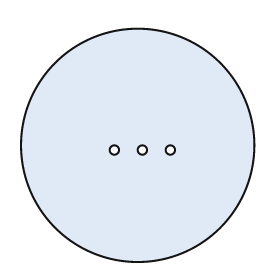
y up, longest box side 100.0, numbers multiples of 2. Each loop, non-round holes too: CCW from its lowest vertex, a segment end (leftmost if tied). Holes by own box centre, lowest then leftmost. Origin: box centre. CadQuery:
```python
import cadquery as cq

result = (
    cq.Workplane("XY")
    .moveTo(0.0, 0.0)
    .circle(50.0)
    .moveTo(-10.0, -2.0)
    .circle(2.0)
    .moveTo(2.0, -2.0)
    .circle(2.0)
    .moveTo(14.0, -2.0)
    .circle(2.0)
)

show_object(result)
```